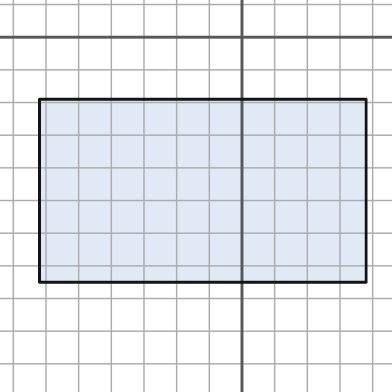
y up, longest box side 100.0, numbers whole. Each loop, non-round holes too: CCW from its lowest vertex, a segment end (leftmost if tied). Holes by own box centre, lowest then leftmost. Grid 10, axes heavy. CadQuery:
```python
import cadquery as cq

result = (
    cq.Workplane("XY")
    .moveTo(-62.0, -75.0)
    .lineTo(38.0, -75.0)
    .lineTo(38.0, -19.0)
    .lineTo(-62.0, -19.0)
    .close()
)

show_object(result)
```